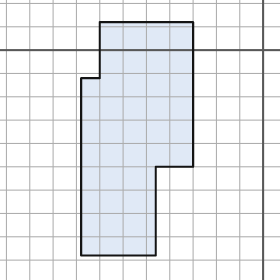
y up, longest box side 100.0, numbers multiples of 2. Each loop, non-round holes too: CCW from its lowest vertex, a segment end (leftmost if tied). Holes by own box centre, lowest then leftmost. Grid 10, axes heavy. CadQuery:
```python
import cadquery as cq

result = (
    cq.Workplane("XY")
    .moveTo(-78.0, -88.0)
    .lineTo(-46.0, -88.0)
    .lineTo(-46.0, -50.0)
    .lineTo(-30.0, -50.0)
    .lineTo(-30.0, 12.0)
    .lineTo(-70.0, 12.0)
    .lineTo(-70.0, -12.0)
    .lineTo(-78.0, -12.0)
    .close()
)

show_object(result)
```